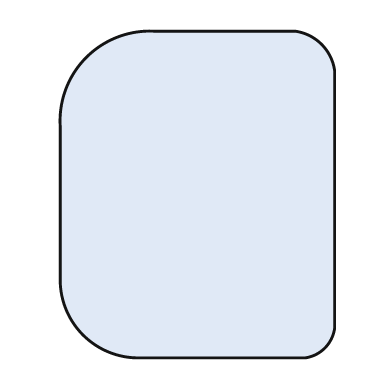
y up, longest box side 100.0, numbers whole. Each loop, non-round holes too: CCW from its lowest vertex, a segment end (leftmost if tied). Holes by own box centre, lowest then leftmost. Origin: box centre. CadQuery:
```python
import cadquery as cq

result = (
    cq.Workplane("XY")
    .moveTo(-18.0, -50.0)
    .lineTo(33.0, -50.0)
    .threePointArc((39.0, -47.0), (42.0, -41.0))
    .lineTo(42.0, 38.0)
    .threePointArc((38.0, 46.0), (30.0, 50.0))
    .lineTo(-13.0, 50.0)
    .threePointArc((-34.0, 42.0), (-42.0, 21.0))
    .lineTo(-42.0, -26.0)
    .threePointArc((-35.0, -43.0), (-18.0, -50.0))
    .close()
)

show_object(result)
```